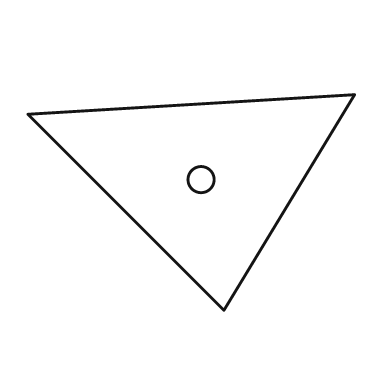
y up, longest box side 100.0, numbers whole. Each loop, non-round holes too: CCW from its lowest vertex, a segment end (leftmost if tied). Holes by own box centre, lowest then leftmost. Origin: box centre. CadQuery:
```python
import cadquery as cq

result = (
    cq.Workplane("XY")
    .moveTo(10.0, -33.0)
    .lineTo(50.0, 33.0)
    .lineTo(-50.0, 27.0)
    .close()
    .moveTo(3.0, 7.0)
    .circle(4.0)
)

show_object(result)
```